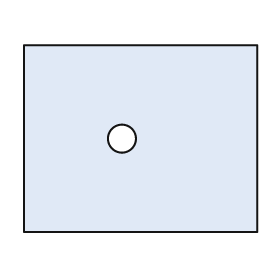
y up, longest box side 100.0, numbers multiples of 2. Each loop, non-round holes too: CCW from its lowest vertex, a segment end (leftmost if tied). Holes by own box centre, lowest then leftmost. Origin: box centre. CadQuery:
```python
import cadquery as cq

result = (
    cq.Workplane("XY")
    .moveTo(-50.0, -40.0)
    .lineTo(50.0, -40.0)
    .lineTo(50.0, 40.0)
    .lineTo(-50.0, 40.0)
    .close()
    .moveTo(-8.0, 0.0)
    .circle(6.0)
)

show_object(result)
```